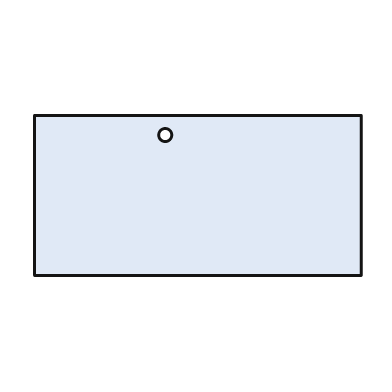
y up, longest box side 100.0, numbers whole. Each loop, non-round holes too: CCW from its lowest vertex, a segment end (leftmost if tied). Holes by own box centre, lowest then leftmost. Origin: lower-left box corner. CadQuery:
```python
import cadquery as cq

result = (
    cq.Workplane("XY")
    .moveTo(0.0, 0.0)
    .lineTo(100.0, 0.0)
    .lineTo(100.0, 49.0)
    .lineTo(0.0, 49.0)
    .close()
    .moveTo(40.0, 43.0)
    .circle(2.0)
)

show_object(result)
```